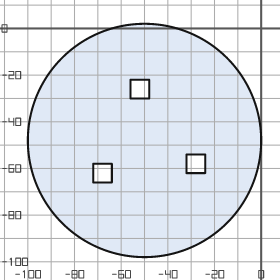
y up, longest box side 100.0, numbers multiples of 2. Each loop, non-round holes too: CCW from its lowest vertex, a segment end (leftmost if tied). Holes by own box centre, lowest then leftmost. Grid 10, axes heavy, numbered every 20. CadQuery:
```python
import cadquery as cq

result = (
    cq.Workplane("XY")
    .moveTo(-50.0, -48.0)
    .circle(50.0)
    .moveTo(-72.0, -66.0)
    .lineTo(-64.0, -66.0)
    .lineTo(-64.0, -58.0)
    .lineTo(-72.0, -58.0)
    .close()
    .moveTo(-32.0, -62.0)
    .lineTo(-24.0, -62.0)
    .lineTo(-24.0, -54.0)
    .lineTo(-32.0, -54.0)
    .close()
    .moveTo(-56.0, -30.0)
    .lineTo(-48.0, -30.0)
    .lineTo(-48.0, -22.0)
    .lineTo(-56.0, -22.0)
    .close()
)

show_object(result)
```